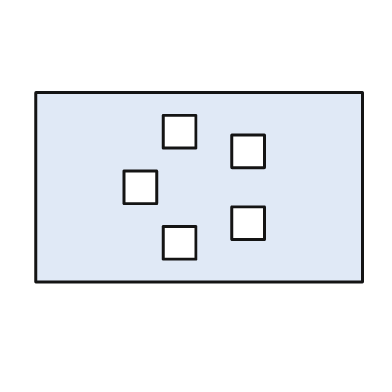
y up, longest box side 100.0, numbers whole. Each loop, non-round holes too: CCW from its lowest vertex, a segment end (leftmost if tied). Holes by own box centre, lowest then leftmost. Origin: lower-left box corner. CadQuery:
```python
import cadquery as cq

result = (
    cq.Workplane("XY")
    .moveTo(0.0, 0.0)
    .lineTo(100.0, 0.0)
    .lineTo(100.0, 58.0)
    .lineTo(0.0, 58.0)
    .close()
    .moveTo(39.0, 7.0)
    .lineTo(49.0, 7.0)
    .lineTo(49.0, 17.0)
    .lineTo(39.0, 17.0)
    .close()
    .moveTo(60.0, 13.0)
    .lineTo(70.0, 13.0)
    .lineTo(70.0, 23.0)
    .lineTo(60.0, 23.0)
    .close()
    .moveTo(27.0, 24.0)
    .lineTo(37.0, 24.0)
    .lineTo(37.0, 34.0)
    .lineTo(27.0, 34.0)
    .close()
    .moveTo(60.0, 35.0)
    .lineTo(70.0, 35.0)
    .lineTo(70.0, 45.0)
    .lineTo(60.0, 45.0)
    .close()
    .moveTo(39.0, 41.0)
    .lineTo(49.0, 41.0)
    .lineTo(49.0, 51.0)
    .lineTo(39.0, 51.0)
    .close()
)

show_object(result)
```